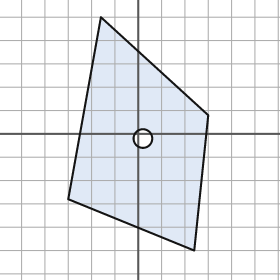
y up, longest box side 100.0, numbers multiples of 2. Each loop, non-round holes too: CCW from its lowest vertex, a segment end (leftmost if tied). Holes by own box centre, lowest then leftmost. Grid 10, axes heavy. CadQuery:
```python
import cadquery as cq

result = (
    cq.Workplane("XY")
    .moveTo(24.0, -50.0)
    .lineTo(30.0, 8.0)
    .lineTo(-16.0, 50.0)
    .lineTo(-30.0, -28.0)
    .close()
    .moveTo(2.0, -2.0)
    .circle(4.0)
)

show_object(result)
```